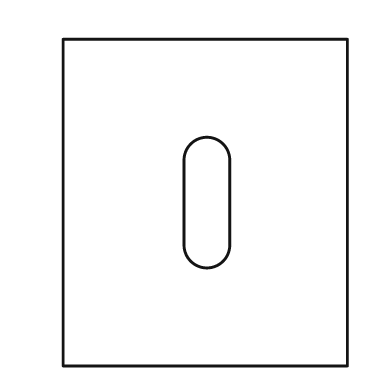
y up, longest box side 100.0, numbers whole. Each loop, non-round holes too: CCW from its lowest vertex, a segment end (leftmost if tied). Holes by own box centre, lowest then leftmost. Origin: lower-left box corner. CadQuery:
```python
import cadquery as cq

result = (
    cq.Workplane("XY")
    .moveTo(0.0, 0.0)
    .lineTo(87.0, 0.0)
    .lineTo(87.0, 100.0)
    .lineTo(0.0, 100.0)
    .close()
    .moveTo(37.0, 37.0)
    .threePointArc((44.0, 30.0), (51.0, 37.0))
    .lineTo(51.0, 63.0)
    .threePointArc((44.0, 70.0), (37.0, 63.0))
    .close()
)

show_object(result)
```